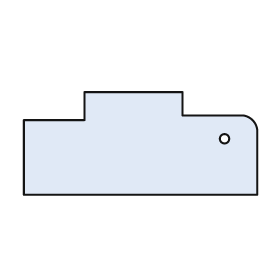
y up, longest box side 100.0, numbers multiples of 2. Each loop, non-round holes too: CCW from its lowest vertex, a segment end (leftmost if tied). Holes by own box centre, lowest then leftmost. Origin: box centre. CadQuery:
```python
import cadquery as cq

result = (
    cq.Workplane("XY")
    .moveTo(-50.0, -22.0)
    .lineTo(50.0, -22.0)
    .lineTo(50.0, 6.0)
    .threePointArc((48.0, 10.0), (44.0, 12.0))
    .lineTo(18.0, 12.0)
    .lineTo(18.0, 22.0)
    .lineTo(-24.0, 22.0)
    .lineTo(-24.0, 10.0)
    .lineTo(-50.0, 10.0)
    .close()
    .moveTo(36.0, 2.0)
    .circle(2.0)
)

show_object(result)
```